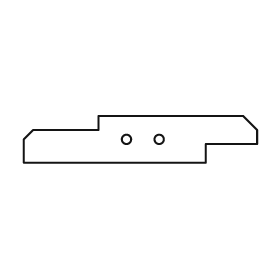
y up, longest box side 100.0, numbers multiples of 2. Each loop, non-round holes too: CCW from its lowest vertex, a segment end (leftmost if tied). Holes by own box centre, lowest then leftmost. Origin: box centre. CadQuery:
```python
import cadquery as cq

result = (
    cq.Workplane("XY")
    .moveTo(-50.0, -10.0)
    .lineTo(28.0, -10.0)
    .lineTo(28.0, -2.0)
    .lineTo(50.0, -2.0)
    .lineTo(50.0, 4.0)
    .lineTo(44.0, 10.0)
    .lineTo(-18.0, 10.0)
    .lineTo(-18.0, 4.0)
    .lineTo(-46.0, 4.0)
    .lineTo(-50.0, 0.0)
    .close()
    .moveTo(-6.0, 0.0)
    .circle(2.0)
    .moveTo(8.0, 0.0)
    .circle(2.0)
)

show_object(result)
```